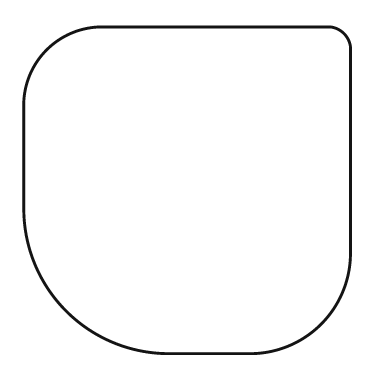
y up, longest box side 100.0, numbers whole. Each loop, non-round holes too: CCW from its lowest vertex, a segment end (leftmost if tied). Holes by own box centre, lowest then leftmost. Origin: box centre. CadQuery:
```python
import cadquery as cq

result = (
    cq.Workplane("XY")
    .moveTo(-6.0, -50.0)
    .lineTo(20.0, -50.0)
    .threePointArc((41.0, -41.0), (50.0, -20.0))
    .lineTo(50.0, 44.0)
    .threePointArc((48.0, 48.0), (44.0, 50.0))
    .lineTo(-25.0, 50.0)
    .threePointArc((-43.0, 43.0), (-50.0, 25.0))
    .lineTo(-50.0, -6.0)
    .threePointArc((-37.0, -37.0), (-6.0, -50.0))
    .close()
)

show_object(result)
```